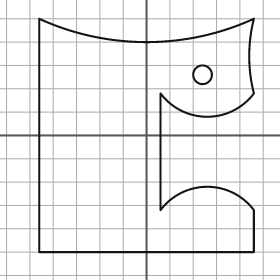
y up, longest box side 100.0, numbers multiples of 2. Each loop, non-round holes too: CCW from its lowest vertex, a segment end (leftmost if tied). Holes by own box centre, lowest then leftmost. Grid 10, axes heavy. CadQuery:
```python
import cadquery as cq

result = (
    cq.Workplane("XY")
    .moveTo(-46.0, -50.0)
    .lineTo(46.0, -50.0)
    .lineTo(46.0, -32.0)
    .threePointArc((26.0, -22.0), (6.0, -32.0))
    .lineTo(6.0, 18.0)
    .threePointArc((26.0, 8.0), (46.0, 18.0))
    .threePointArc((44.0, 34.0), (46.0, 50.0))
    .threePointArc((0.0, 40.0), (-46.0, 50.0))
    .close()
    .moveTo(24.0, 26.0)
    .circle(4.0)
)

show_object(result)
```